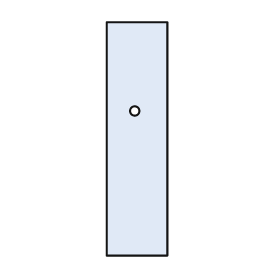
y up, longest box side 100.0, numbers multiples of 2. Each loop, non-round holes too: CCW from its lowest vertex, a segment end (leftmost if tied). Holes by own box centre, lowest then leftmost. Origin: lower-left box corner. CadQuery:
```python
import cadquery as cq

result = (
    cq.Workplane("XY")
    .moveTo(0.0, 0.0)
    .lineTo(26.0, 0.0)
    .lineTo(26.0, 100.0)
    .lineTo(0.0, 100.0)
    .close()
    .moveTo(12.0, 62.0)
    .circle(2.0)
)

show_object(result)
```